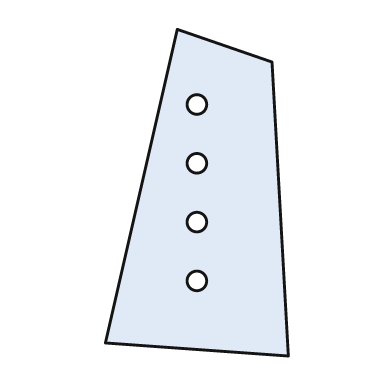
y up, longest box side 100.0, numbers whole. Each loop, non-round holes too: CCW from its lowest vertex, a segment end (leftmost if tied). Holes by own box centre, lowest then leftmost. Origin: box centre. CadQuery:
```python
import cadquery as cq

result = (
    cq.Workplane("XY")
    .moveTo(28.0, -50.0)
    .lineTo(23.0, 40.0)
    .lineTo(-6.0, 50.0)
    .lineTo(-28.0, -46.0)
    .close()
    .moveTo(0.0, -27.0)
    .circle(3.0)
    .moveTo(0.0, -9.0)
    .circle(3.0)
    .moveTo(0.0, 9.0)
    .circle(3.0)
    .moveTo(0.0, 27.0)
    .circle(3.0)
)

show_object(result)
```